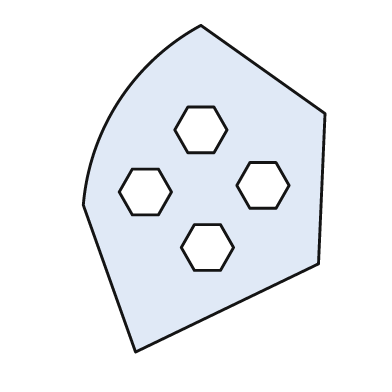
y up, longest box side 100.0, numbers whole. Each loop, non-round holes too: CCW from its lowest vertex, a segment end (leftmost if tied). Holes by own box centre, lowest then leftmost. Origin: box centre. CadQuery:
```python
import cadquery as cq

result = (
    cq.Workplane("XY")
    .moveTo(-21.0, -50.0)
    .lineTo(35.0, -23.0)
    .lineTo(37.0, 23.0)
    .lineTo(-1.0, 50.0)
    .threePointArc((-26.0, 27.0), (-37.0, -5.0))
    .close()
    .moveTo(-3.0, -25.0)
    .lineTo(5.0, -25.0)
    .lineTo(9.0, -18.0)
    .lineTo(5.0, -11.0)
    .lineTo(-3.0, -11.0)
    .lineTo(-7.0, -18.0)
    .close()
    .moveTo(-22.0, -8.0)
    .lineTo(-14.0, -8.0)
    .lineTo(-10.0, -1.0)
    .lineTo(-14.0, 6.0)
    .lineTo(-22.0, 6.0)
    .lineTo(-26.0, -1.0)
    .close()
    .moveTo(14.0, -6.0)
    .lineTo(22.0, -6.0)
    .lineTo(26.0, 1.0)
    .lineTo(22.0, 8.0)
    .lineTo(14.0, 8.0)
    .lineTo(10.0, 1.0)
    .close()
    .moveTo(-5.0, 11.0)
    .lineTo(3.0, 11.0)
    .lineTo(7.0, 18.0)
    .lineTo(3.0, 25.0)
    .lineTo(-5.0, 25.0)
    .lineTo(-9.0, 18.0)
    .close()
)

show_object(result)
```